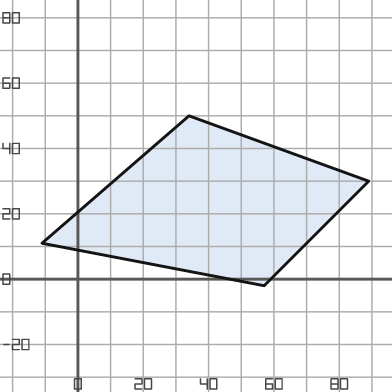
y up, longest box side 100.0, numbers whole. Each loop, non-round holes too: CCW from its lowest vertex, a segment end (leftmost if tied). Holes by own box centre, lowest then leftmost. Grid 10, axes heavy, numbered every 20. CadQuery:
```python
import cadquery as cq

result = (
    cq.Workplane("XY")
    .moveTo(57.0, -2.0)
    .lineTo(89.0, 30.0)
    .lineTo(34.0, 50.0)
    .lineTo(-11.0, 11.0)
    .close()
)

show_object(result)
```